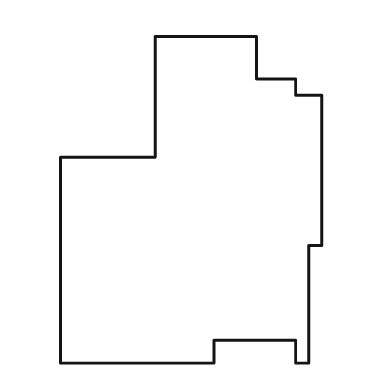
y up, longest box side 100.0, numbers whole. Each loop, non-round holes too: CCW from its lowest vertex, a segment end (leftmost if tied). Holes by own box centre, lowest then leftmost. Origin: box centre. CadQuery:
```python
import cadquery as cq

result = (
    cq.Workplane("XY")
    .moveTo(-40.0, -50.0)
    .lineTo(7.0, -50.0)
    .lineTo(7.0, -43.0)
    .lineTo(32.0, -43.0)
    .lineTo(32.0, -50.0)
    .lineTo(36.0, -50.0)
    .lineTo(36.0, -14.0)
    .lineTo(40.0, -14.0)
    .lineTo(40.0, 32.0)
    .lineTo(32.0, 32.0)
    .lineTo(32.0, 37.0)
    .lineTo(20.0, 37.0)
    .lineTo(20.0, 50.0)
    .lineTo(-11.0, 50.0)
    .lineTo(-11.0, 13.0)
    .lineTo(-40.0, 13.0)
    .close()
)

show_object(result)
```